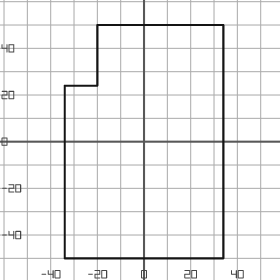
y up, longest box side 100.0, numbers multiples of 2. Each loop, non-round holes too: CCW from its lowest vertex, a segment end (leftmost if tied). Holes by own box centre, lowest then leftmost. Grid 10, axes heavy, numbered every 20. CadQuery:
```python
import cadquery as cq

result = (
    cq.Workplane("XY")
    .moveTo(-34.0, -50.0)
    .lineTo(34.0, -50.0)
    .lineTo(34.0, 50.0)
    .lineTo(-20.0, 50.0)
    .lineTo(-20.0, 24.0)
    .lineTo(-34.0, 24.0)
    .close()
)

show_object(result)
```